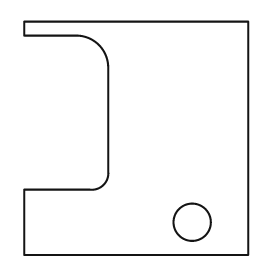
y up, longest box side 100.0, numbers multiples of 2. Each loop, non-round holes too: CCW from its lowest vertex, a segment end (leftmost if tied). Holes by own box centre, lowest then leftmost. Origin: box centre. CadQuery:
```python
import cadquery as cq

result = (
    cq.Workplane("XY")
    .moveTo(-48.0, -50.0)
    .lineTo(48.0, -50.0)
    .lineTo(48.0, 50.0)
    .lineTo(-48.0, 50.0)
    .lineTo(-48.0, 44.0)
    .lineTo(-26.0, 44.0)
    .threePointArc((-16.0, 40.0), (-12.0, 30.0))
    .lineTo(-12.0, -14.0)
    .threePointArc((-14.0, -20.0), (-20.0, -22.0))
    .lineTo(-48.0, -22.0)
    .close()
    .moveTo(24.0, -36.0)
    .circle(8.0)
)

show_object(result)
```